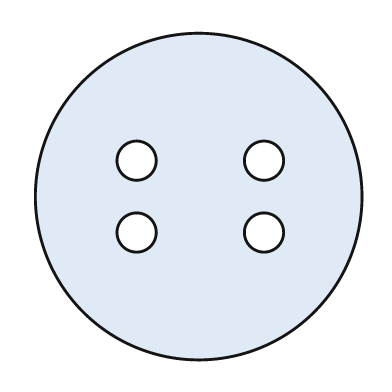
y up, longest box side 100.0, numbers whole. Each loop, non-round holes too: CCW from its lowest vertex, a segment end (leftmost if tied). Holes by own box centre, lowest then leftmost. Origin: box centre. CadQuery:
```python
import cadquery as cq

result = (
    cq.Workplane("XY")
    .moveTo(0.0, 0.0)
    .circle(50.0)
    .moveTo(-19.0, -11.0)
    .circle(6.0)
    .moveTo(20.0, -11.0)
    .circle(6.0)
    .moveTo(-19.0, 11.0)
    .circle(6.0)
    .moveTo(20.0, 11.0)
    .circle(6.0)
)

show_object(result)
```